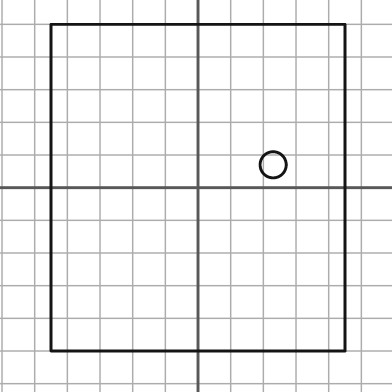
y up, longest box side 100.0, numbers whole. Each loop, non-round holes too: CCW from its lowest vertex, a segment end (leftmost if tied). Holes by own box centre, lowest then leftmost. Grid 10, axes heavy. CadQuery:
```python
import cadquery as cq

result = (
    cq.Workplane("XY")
    .moveTo(-45.0, -50.0)
    .lineTo(45.0, -50.0)
    .lineTo(45.0, 50.0)
    .lineTo(-45.0, 50.0)
    .close()
    .moveTo(23.0, 7.0)
    .circle(4.0)
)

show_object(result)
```